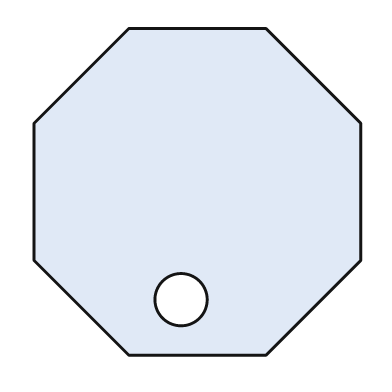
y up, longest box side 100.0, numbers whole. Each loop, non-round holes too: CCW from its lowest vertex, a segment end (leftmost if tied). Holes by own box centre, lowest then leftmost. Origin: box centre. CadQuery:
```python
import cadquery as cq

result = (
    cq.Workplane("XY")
    .moveTo(-21.0, -50.0)
    .lineTo(21.0, -50.0)
    .lineTo(50.0, -21.0)
    .lineTo(50.0, 21.0)
    .lineTo(21.0, 50.0)
    .lineTo(-21.0, 50.0)
    .lineTo(-50.0, 21.0)
    .lineTo(-50.0, -21.0)
    .close()
    .moveTo(-5.0, -33.0)
    .circle(8.0)
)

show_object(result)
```